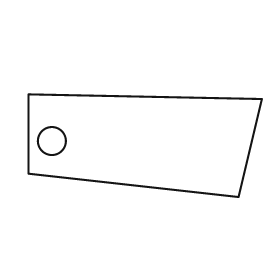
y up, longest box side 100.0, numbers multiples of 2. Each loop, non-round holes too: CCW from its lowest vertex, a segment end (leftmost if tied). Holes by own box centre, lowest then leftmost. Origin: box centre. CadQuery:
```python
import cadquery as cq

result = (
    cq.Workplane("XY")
    .moveTo(40.0, -22.0)
    .lineTo(50.0, 20.0)
    .lineTo(-50.0, 22.0)
    .lineTo(-50.0, -12.0)
    .close()
    .moveTo(-40.0, 2.0)
    .circle(6.0)
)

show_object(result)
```